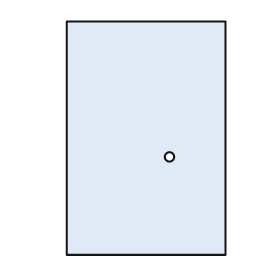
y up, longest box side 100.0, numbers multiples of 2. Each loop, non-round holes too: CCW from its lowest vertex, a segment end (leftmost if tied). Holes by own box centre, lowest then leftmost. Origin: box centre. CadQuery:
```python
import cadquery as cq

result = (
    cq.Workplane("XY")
    .moveTo(-34.0, -50.0)
    .lineTo(34.0, -50.0)
    .lineTo(34.0, 50.0)
    .lineTo(-34.0, 50.0)
    .close()
    .moveTo(10.0, -8.0)
    .circle(2.0)
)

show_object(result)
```